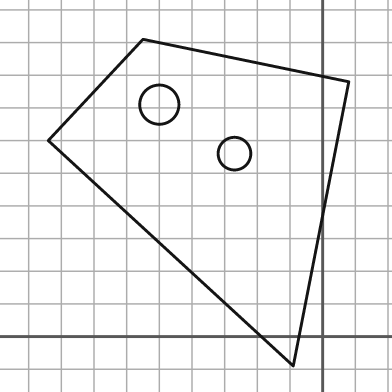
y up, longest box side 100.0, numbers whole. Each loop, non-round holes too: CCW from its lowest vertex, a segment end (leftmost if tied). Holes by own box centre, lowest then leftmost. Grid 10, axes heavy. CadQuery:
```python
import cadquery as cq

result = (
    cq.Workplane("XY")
    .moveTo(-9.0, -9.0)
    .lineTo(8.0, 78.0)
    .lineTo(-55.0, 91.0)
    .lineTo(-84.0, 60.0)
    .close()
    .moveTo(-27.0, 56.0)
    .circle(5.0)
    .moveTo(-50.0, 71.0)
    .circle(6.0)
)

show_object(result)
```